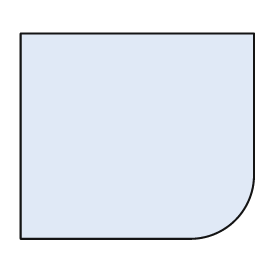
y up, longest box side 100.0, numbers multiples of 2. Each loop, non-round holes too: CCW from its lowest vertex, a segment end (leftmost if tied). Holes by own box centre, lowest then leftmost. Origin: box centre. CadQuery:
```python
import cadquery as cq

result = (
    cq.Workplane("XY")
    .moveTo(-50.0, -44.0)
    .lineTo(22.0, -44.0)
    .threePointArc((42.0, -36.0), (50.0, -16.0))
    .lineTo(50.0, 44.0)
    .lineTo(-50.0, 44.0)
    .close()
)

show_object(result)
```